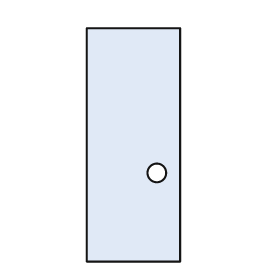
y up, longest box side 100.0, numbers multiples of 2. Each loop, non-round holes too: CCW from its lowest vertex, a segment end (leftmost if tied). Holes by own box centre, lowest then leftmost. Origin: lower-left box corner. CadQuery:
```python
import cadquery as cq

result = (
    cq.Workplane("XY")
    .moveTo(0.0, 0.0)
    .lineTo(40.0, 0.0)
    .lineTo(40.0, 100.0)
    .lineTo(0.0, 100.0)
    .close()
    .moveTo(30.0, 38.0)
    .circle(4.0)
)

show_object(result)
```